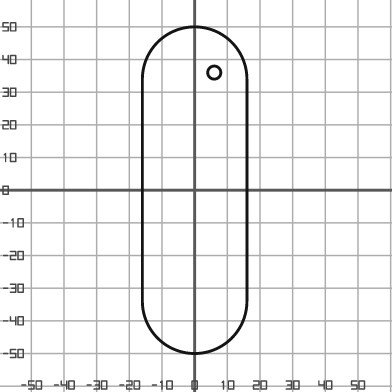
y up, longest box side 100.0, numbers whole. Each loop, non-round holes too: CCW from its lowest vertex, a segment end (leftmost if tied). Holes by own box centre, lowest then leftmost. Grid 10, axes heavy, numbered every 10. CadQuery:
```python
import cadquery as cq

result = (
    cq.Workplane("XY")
    .moveTo(-16.0, -34.0)
    .threePointArc((0.0, -50.0), (16.0, -34.0))
    .lineTo(16.0, 34.0)
    .threePointArc((0.0, 50.0), (-16.0, 34.0))
    .close()
    .moveTo(6.0, 36.0)
    .circle(2.0)
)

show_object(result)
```